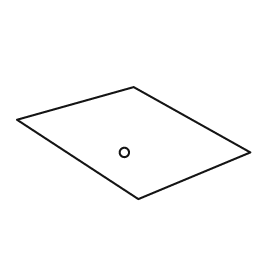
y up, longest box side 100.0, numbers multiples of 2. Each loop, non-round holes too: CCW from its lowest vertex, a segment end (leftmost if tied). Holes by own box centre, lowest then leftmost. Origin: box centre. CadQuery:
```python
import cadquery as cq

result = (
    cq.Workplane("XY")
    .moveTo(2.0, -24.0)
    .lineTo(50.0, -4.0)
    .lineTo(0.0, 24.0)
    .lineTo(-50.0, 10.0)
    .close()
    .moveTo(-4.0, -4.0)
    .circle(2.0)
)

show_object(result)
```